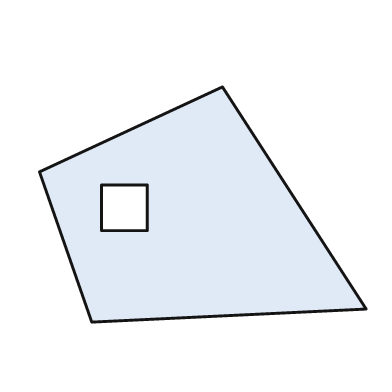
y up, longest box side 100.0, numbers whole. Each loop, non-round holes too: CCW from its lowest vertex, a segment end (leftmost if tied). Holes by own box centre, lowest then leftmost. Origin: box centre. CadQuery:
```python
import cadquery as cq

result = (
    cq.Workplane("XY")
    .moveTo(-34.0, -36.0)
    .lineTo(50.0, -32.0)
    .lineTo(6.0, 36.0)
    .lineTo(-50.0, 10.0)
    .close()
    .moveTo(-31.0, -8.0)
    .lineTo(-17.0, -8.0)
    .lineTo(-17.0, 6.0)
    .lineTo(-31.0, 6.0)
    .close()
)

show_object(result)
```